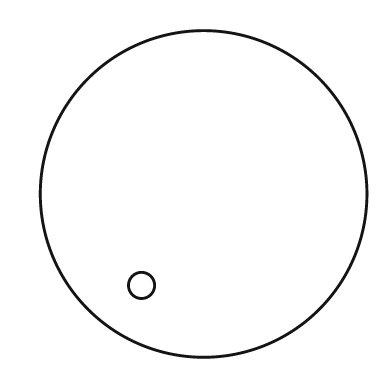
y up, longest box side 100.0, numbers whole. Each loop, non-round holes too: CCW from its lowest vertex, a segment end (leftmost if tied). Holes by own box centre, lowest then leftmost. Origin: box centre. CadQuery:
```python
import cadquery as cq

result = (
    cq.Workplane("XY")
    .moveTo(0.0, 0.0)
    .circle(50.0)
    .moveTo(-19.0, -28.0)
    .circle(4.0)
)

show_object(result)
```